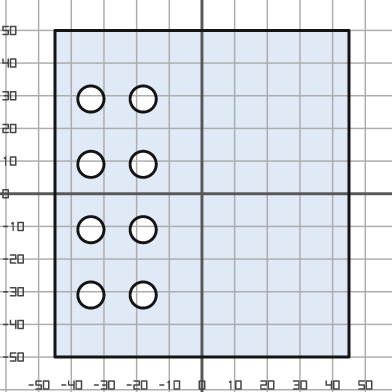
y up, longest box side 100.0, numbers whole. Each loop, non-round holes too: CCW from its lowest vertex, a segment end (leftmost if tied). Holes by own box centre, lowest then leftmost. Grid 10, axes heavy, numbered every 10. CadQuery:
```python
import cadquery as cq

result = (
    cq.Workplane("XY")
    .moveTo(-45.0, -50.0)
    .lineTo(45.0, -50.0)
    .lineTo(45.0, 50.0)
    .lineTo(-45.0, 50.0)
    .close()
    .moveTo(-34.0, -31.0)
    .circle(4.0)
    .moveTo(-18.0, -31.0)
    .circle(4.0)
    .moveTo(-34.0, -11.0)
    .circle(4.0)
    .moveTo(-18.0, -11.0)
    .circle(4.0)
    .moveTo(-34.0, 9.0)
    .circle(4.0)
    .moveTo(-18.0, 9.0)
    .circle(4.0)
    .moveTo(-34.0, 29.0)
    .circle(4.0)
    .moveTo(-18.0, 29.0)
    .circle(4.0)
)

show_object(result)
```